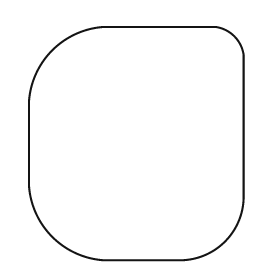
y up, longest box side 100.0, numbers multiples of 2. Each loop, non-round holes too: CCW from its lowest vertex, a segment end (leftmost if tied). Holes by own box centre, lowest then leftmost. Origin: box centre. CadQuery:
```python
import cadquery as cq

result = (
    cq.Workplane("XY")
    .moveTo(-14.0, -50.0)
    .lineTo(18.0, -50.0)
    .threePointArc((38.0, -42.0), (46.0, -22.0))
    .lineTo(46.0, 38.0)
    .threePointArc((42.0, 46.0), (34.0, 50.0))
    .lineTo(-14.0, 50.0)
    .threePointArc((-36.0, 40.0), (-46.0, 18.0))
    .lineTo(-46.0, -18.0)
    .threePointArc((-36.0, -40.0), (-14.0, -50.0))
    .close()
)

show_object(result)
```